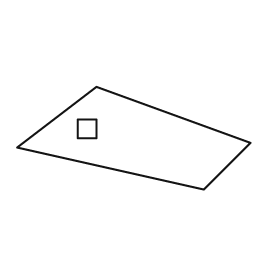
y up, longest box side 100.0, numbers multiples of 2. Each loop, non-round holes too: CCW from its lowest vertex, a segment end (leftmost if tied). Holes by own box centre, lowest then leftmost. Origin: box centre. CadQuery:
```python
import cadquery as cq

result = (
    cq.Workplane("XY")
    .moveTo(30.0, -22.0)
    .lineTo(50.0, -2.0)
    .lineTo(-16.0, 22.0)
    .lineTo(-50.0, -4.0)
    .close()
    .moveTo(-24.0, 0.0)
    .lineTo(-16.0, 0.0)
    .lineTo(-16.0, 8.0)
    .lineTo(-24.0, 8.0)
    .close()
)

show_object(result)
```